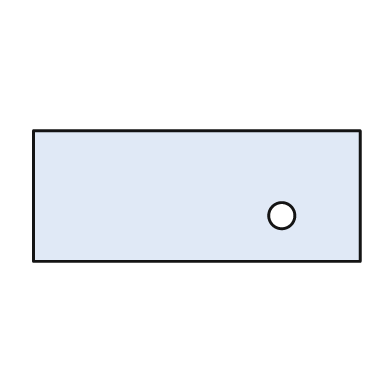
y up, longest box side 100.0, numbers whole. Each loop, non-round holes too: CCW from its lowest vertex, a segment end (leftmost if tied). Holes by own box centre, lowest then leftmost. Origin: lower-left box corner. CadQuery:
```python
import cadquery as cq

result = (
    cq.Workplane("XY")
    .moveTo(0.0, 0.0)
    .lineTo(100.0, 0.0)
    .lineTo(100.0, 40.0)
    .lineTo(0.0, 40.0)
    .close()
    .moveTo(76.0, 14.0)
    .circle(4.0)
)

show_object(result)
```